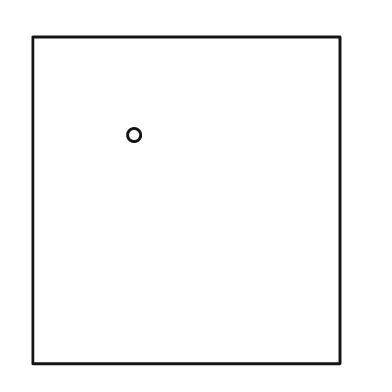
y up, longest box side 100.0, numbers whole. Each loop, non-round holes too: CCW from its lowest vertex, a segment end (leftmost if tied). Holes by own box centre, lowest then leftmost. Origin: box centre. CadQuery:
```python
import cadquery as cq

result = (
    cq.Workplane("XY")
    .moveTo(-47.0, -50.0)
    .lineTo(47.0, -50.0)
    .lineTo(47.0, 50.0)
    .lineTo(-47.0, 50.0)
    .close()
    .moveTo(-16.0, 20.0)
    .circle(2.0)
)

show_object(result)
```